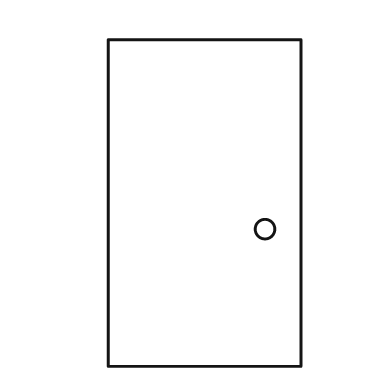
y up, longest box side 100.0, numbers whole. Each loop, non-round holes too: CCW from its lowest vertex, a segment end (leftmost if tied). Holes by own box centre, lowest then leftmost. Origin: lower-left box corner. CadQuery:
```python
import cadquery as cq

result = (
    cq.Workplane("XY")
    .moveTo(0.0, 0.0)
    .lineTo(59.0, 0.0)
    .lineTo(59.0, 100.0)
    .lineTo(0.0, 100.0)
    .close()
    .moveTo(48.0, 42.0)
    .circle(3.0)
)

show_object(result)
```